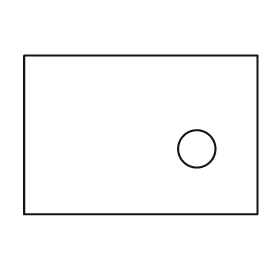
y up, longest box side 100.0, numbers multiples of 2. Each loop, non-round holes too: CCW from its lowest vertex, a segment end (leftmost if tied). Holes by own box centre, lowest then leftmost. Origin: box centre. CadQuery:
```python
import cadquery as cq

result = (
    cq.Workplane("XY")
    .moveTo(-50.0, -34.0)
    .lineTo(50.0, -34.0)
    .lineTo(50.0, 34.0)
    .lineTo(-50.0, 34.0)
    .close()
    .moveTo(24.0, -6.0)
    .circle(8.0)
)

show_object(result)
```